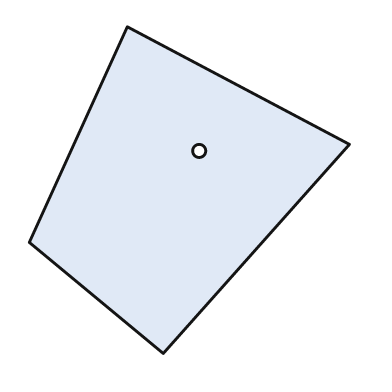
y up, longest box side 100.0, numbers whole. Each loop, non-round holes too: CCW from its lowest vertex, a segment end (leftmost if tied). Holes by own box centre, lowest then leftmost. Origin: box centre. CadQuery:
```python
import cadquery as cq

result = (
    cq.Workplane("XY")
    .moveTo(-8.0, -50.0)
    .lineTo(49.0, 14.0)
    .lineTo(-19.0, 50.0)
    .lineTo(-49.0, -16.0)
    .close()
    .moveTo(3.0, 12.0)
    .circle(2.0)
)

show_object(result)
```